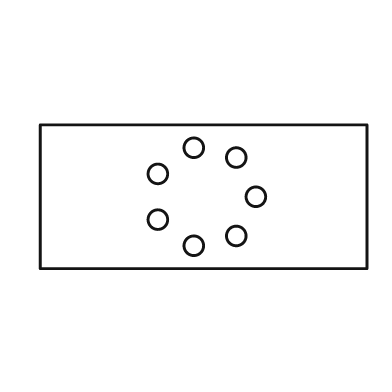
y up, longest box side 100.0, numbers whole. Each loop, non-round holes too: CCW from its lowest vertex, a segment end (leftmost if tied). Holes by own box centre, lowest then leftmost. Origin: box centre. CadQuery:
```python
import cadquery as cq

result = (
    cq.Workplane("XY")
    .moveTo(-50.0, -22.0)
    .lineTo(50.0, -22.0)
    .lineTo(50.0, 22.0)
    .lineTo(-50.0, 22.0)
    .close()
    .moveTo(-3.0, -15.0)
    .circle(3.0)
    .moveTo(10.0, -12.0)
    .circle(3.0)
    .moveTo(-14.0, -7.0)
    .circle(3.0)
    .moveTo(16.0, 0.0)
    .circle(3.0)
    .moveTo(-14.0, 7.0)
    .circle(3.0)
    .moveTo(10.0, 12.0)
    .circle(3.0)
    .moveTo(-3.0, 15.0)
    .circle(3.0)
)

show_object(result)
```